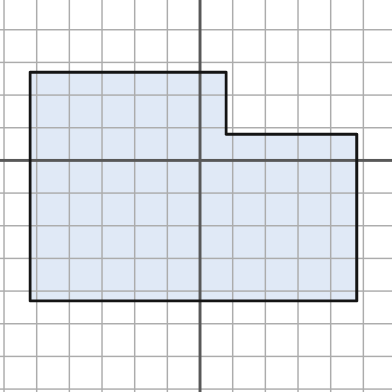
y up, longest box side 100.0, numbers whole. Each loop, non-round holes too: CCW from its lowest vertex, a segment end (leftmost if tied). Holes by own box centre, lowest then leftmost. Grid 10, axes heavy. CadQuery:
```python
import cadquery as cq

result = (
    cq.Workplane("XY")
    .moveTo(-52.0, -43.0)
    .lineTo(48.0, -43.0)
    .lineTo(48.0, 8.0)
    .lineTo(8.0, 8.0)
    .lineTo(8.0, 27.0)
    .lineTo(-52.0, 27.0)
    .close()
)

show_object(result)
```